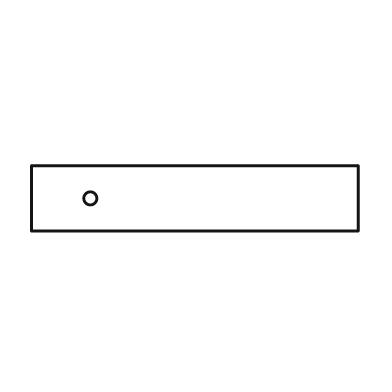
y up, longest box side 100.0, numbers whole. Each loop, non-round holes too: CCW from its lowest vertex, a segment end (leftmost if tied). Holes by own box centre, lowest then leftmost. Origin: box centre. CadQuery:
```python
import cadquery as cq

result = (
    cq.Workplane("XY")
    .moveTo(-50.0, -10.0)
    .lineTo(50.0, -10.0)
    .lineTo(50.0, 10.0)
    .lineTo(-50.0, 10.0)
    .close()
    .moveTo(-32.0, 0.0)
    .circle(2.0)
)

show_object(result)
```